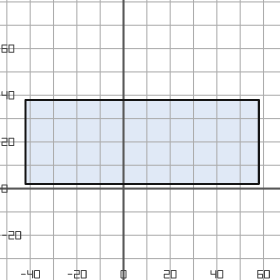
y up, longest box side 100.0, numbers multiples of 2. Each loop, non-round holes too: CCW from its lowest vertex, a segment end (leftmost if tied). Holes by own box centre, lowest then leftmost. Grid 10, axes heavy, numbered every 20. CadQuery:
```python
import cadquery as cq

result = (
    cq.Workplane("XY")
    .moveTo(-42.0, 2.0)
    .lineTo(58.0, 2.0)
    .lineTo(58.0, 38.0)
    .lineTo(-42.0, 38.0)
    .close()
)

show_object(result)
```